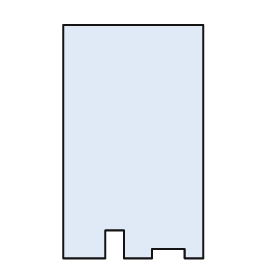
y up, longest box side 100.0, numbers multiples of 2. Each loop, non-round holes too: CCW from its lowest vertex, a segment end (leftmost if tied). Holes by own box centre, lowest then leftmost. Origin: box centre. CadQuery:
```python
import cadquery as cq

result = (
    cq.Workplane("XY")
    .moveTo(-30.0, -50.0)
    .lineTo(-12.0, -50.0)
    .lineTo(-12.0, -38.0)
    .lineTo(-4.0, -38.0)
    .lineTo(-4.0, -50.0)
    .lineTo(8.0, -50.0)
    .lineTo(8.0, -46.0)
    .lineTo(22.0, -46.0)
    .lineTo(22.0, -50.0)
    .lineTo(30.0, -50.0)
    .lineTo(30.0, 50.0)
    .lineTo(-30.0, 50.0)
    .close()
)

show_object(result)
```